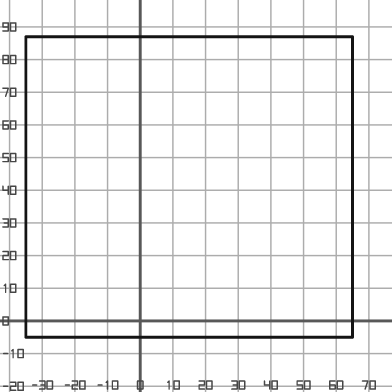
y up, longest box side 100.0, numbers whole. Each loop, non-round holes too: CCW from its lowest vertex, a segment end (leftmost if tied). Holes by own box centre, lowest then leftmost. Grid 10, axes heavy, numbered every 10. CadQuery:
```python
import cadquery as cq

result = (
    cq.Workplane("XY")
    .moveTo(-35.0, -5.0)
    .lineTo(65.0, -5.0)
    .lineTo(65.0, 87.0)
    .lineTo(-35.0, 87.0)
    .close()
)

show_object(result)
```